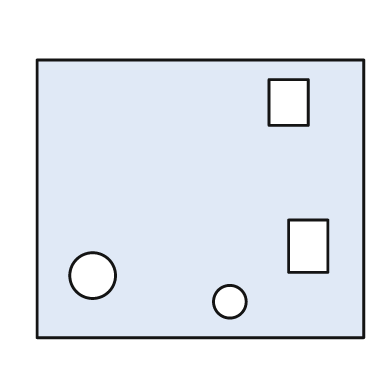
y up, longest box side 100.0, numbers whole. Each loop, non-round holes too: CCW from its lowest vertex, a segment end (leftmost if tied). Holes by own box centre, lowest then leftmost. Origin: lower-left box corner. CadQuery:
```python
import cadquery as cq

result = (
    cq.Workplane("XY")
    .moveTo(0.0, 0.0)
    .lineTo(100.0, 0.0)
    .lineTo(100.0, 85.0)
    .lineTo(0.0, 85.0)
    .close()
    .moveTo(59.0, 11.0)
    .circle(5.0)
    .moveTo(17.0, 19.0)
    .circle(7.0)
    .moveTo(77.0, 20.0)
    .lineTo(89.0, 20.0)
    .lineTo(89.0, 36.0)
    .lineTo(77.0, 36.0)
    .close()
    .moveTo(71.0, 65.0)
    .lineTo(83.0, 65.0)
    .lineTo(83.0, 79.0)
    .lineTo(71.0, 79.0)
    .close()
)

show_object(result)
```